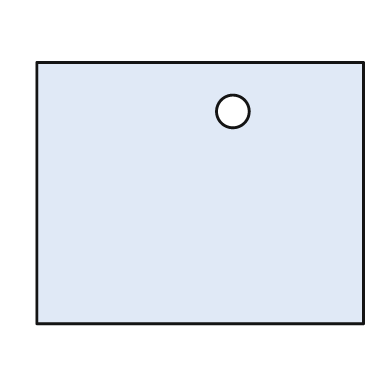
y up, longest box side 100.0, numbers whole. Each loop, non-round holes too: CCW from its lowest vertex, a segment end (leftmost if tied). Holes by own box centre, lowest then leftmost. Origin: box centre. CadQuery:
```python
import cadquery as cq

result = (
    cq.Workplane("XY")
    .moveTo(-50.0, -40.0)
    .lineTo(50.0, -40.0)
    .lineTo(50.0, 40.0)
    .lineTo(-50.0, 40.0)
    .close()
    .moveTo(10.0, 25.0)
    .circle(5.0)
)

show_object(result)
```